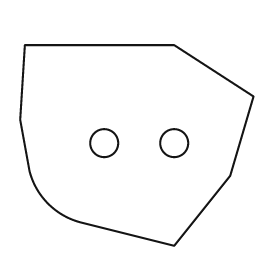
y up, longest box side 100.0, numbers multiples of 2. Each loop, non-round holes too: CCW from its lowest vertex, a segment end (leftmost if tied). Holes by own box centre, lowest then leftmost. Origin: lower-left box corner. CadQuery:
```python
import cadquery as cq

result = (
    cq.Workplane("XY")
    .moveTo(66.0, 0.0)
    .lineTo(90.0, 30.0)
    .lineTo(100.0, 64.0)
    .lineTo(66.0, 86.0)
    .lineTo(2.0, 86.0)
    .lineTo(0.0, 54.0)
    .lineTo(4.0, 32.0)
    .threePointArc((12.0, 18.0), (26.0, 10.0))
    .close()
    .moveTo(36.0, 44.0)
    .circle(6.0)
    .moveTo(66.0, 44.0)
    .circle(6.0)
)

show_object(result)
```